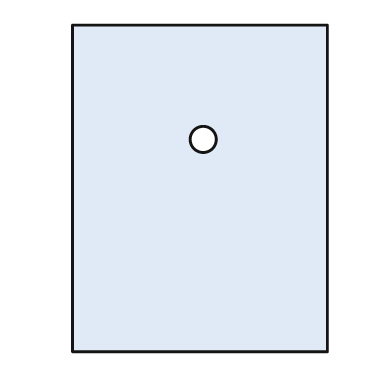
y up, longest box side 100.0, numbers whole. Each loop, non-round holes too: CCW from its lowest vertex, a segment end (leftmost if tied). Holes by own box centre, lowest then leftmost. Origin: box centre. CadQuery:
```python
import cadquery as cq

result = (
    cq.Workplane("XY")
    .moveTo(-39.0, -50.0)
    .lineTo(39.0, -50.0)
    .lineTo(39.0, 50.0)
    .lineTo(-39.0, 50.0)
    .close()
    .moveTo(1.0, 15.0)
    .circle(4.0)
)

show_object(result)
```